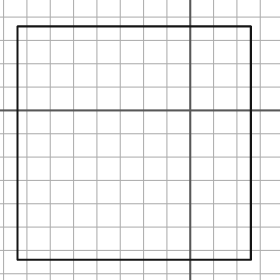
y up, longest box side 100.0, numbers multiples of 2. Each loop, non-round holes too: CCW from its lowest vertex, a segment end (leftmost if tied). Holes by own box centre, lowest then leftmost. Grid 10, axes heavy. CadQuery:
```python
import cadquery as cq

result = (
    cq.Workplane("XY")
    .moveTo(-74.0, -64.0)
    .lineTo(26.0, -64.0)
    .lineTo(26.0, 36.0)
    .lineTo(-74.0, 36.0)
    .close()
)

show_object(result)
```